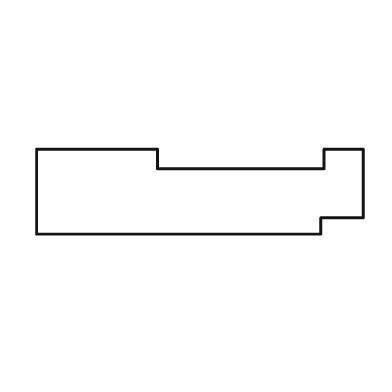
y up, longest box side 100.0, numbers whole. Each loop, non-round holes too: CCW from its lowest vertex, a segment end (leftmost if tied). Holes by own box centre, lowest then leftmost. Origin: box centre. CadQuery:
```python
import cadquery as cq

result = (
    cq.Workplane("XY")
    .moveTo(-50.0, -13.0)
    .lineTo(37.0, -13.0)
    .lineTo(37.0, -8.0)
    .lineTo(50.0, -8.0)
    .lineTo(50.0, 13.0)
    .lineTo(38.0, 13.0)
    .lineTo(38.0, 7.0)
    .lineTo(-13.0, 7.0)
    .lineTo(-13.0, 13.0)
    .lineTo(-50.0, 13.0)
    .close()
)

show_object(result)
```